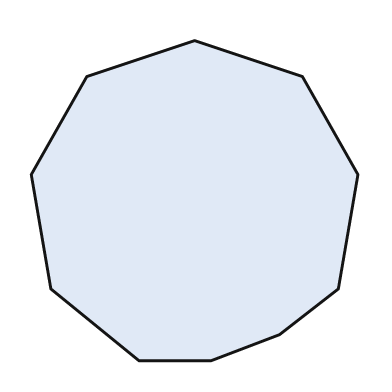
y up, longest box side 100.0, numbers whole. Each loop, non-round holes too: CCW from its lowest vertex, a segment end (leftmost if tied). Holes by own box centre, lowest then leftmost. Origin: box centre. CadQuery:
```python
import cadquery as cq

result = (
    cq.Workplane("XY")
    .moveTo(-17.0, -49.0)
    .lineTo(5.0, -49.0)
    .lineTo(26.0, -41.0)
    .lineTo(44.0, -27.0)
    .lineTo(50.0, 8.0)
    .lineTo(33.0, 38.0)
    .lineTo(0.0, 49.0)
    .lineTo(-33.0, 38.0)
    .lineTo(-50.0, 8.0)
    .lineTo(-44.0, -27.0)
    .close()
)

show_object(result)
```